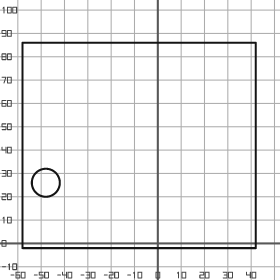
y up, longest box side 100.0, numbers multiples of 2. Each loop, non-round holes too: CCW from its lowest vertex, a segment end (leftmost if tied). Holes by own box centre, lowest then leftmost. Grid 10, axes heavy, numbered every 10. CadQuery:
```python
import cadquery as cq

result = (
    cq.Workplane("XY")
    .moveTo(-58.0, -2.0)
    .lineTo(42.0, -2.0)
    .lineTo(42.0, 86.0)
    .lineTo(-58.0, 86.0)
    .close()
    .moveTo(-48.0, 26.0)
    .circle(6.0)
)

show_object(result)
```